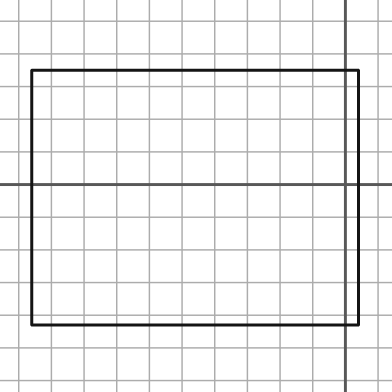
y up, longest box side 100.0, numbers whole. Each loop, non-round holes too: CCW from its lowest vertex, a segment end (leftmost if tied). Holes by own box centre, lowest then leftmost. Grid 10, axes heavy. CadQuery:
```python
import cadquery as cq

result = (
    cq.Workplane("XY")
    .moveTo(-96.0, -43.0)
    .lineTo(4.0, -43.0)
    .lineTo(4.0, 35.0)
    .lineTo(-96.0, 35.0)
    .close()
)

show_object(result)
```